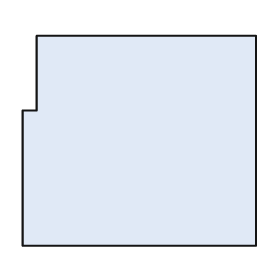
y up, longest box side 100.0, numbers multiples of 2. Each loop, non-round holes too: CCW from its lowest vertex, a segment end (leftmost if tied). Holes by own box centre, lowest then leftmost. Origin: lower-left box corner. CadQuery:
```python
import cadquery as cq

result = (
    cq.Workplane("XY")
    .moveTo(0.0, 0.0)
    .lineTo(100.0, 0.0)
    .lineTo(100.0, 90.0)
    .lineTo(6.0, 90.0)
    .lineTo(6.0, 58.0)
    .lineTo(0.0, 58.0)
    .close()
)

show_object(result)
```